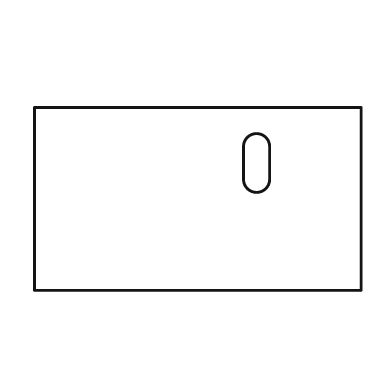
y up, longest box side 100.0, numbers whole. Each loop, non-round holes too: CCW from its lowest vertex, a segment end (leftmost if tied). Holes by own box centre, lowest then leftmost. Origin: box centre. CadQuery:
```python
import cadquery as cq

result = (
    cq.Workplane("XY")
    .moveTo(-50.0, -28.0)
    .lineTo(50.0, -28.0)
    .lineTo(50.0, 28.0)
    .lineTo(-50.0, 28.0)
    .close()
    .moveTo(14.0, 6.0)
    .threePointArc((18.0, 2.0), (22.0, 6.0))
    .lineTo(22.0, 16.0)
    .threePointArc((18.0, 20.0), (14.0, 16.0))
    .close()
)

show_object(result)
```